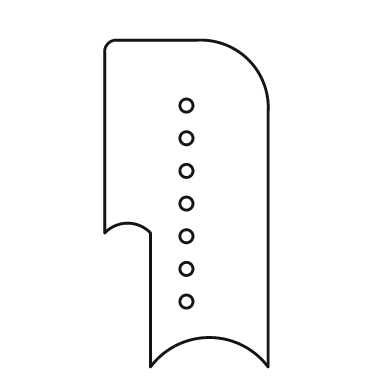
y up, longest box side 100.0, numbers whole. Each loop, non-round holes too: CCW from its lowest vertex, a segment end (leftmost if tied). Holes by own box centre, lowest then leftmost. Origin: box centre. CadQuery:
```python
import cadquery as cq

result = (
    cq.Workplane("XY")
    .moveTo(-11.0, -50.0)
    .threePointArc((7.0, -41.0), (25.0, -50.0))
    .lineTo(25.0, 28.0)
    .threePointArc((19.0, 44.0), (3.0, 50.0))
    .lineTo(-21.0, 50.0)
    .threePointArc((-24.0, 49.0), (-25.0, 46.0))
    .lineTo(-25.0, -9.0)
    .threePointArc((-18.0, -6.0), (-11.0, -9.0))
    .close()
    .moveTo(0.0, -30.0)
    .circle(2.0)
    .moveTo(0.0, -20.0)
    .circle(2.0)
    .moveTo(0.0, -10.0)
    .circle(2.0)
    .moveTo(0.0, 0.0)
    .circle(2.0)
    .moveTo(0.0, 10.0)
    .circle(2.0)
    .moveTo(0.0, 20.0)
    .circle(2.0)
    .moveTo(0.0, 30.0)
    .circle(2.0)
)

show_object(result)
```